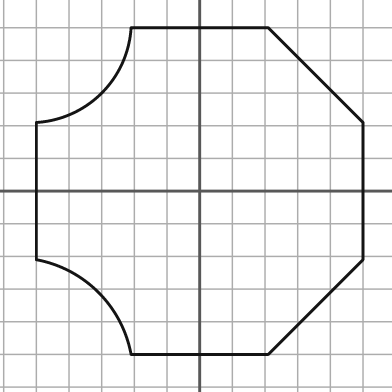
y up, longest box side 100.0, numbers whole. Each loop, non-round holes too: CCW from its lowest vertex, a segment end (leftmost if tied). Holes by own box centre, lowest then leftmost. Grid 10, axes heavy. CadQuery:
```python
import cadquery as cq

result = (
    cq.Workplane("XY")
    .moveTo(-21.0, -50.0)
    .lineTo(21.0, -50.0)
    .lineTo(50.0, -21.0)
    .lineTo(50.0, 21.0)
    .lineTo(21.0, 50.0)
    .lineTo(-21.0, 50.0)
    .threePointArc((-30.0, 30.0), (-50.0, 21.0))
    .lineTo(-50.0, -21.0)
    .threePointArc((-31.0, -31.0), (-21.0, -50.0))
    .close()
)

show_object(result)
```